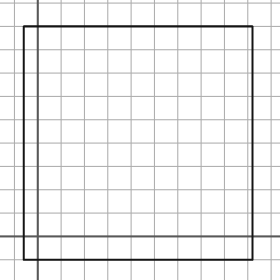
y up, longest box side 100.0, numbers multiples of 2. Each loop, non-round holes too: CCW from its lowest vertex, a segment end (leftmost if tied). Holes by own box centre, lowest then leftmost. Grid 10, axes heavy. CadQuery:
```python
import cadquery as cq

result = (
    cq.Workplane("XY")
    .moveTo(-6.0, -10.0)
    .lineTo(92.0, -10.0)
    .lineTo(92.0, 90.0)
    .lineTo(-6.0, 90.0)
    .close()
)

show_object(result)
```